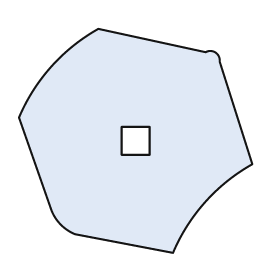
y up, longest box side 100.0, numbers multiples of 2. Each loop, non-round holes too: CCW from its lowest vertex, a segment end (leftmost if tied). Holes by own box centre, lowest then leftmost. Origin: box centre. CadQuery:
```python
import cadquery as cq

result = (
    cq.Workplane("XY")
    .moveTo(16.0, -48.0)
    .threePointArc((30.0, -26.0), (50.0, -10.0))
    .lineTo(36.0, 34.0)
    .threePointArc((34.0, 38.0), (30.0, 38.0))
    .lineTo(-16.0, 48.0)
    .threePointArc((-36.0, 32.0), (-50.0, 10.0))
    .lineTo(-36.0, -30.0)
    .threePointArc((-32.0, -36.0), (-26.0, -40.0))
    .close()
    .moveTo(-6.0, -6.0)
    .lineTo(6.0, -6.0)
    .lineTo(6.0, 6.0)
    .lineTo(-6.0, 6.0)
    .close()
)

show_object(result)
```